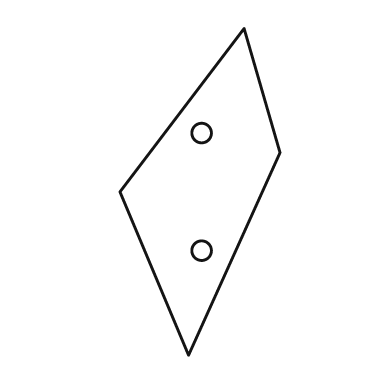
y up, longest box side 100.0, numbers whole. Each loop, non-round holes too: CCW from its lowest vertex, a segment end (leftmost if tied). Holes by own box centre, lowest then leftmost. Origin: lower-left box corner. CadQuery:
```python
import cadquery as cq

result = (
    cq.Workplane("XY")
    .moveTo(21.0, 0.0)
    .lineTo(49.0, 62.0)
    .lineTo(38.0, 100.0)
    .lineTo(0.0, 50.0)
    .close()
    .moveTo(25.0, 32.0)
    .circle(3.0)
    .moveTo(25.0, 68.0)
    .circle(3.0)
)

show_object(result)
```